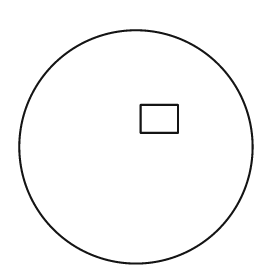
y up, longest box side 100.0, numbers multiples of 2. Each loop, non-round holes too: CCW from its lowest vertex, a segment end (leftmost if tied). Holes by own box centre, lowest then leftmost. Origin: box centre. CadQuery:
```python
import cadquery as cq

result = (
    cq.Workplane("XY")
    .moveTo(0.0, 0.0)
    .circle(50.0)
    .moveTo(2.0, 6.0)
    .lineTo(18.0, 6.0)
    .lineTo(18.0, 18.0)
    .lineTo(2.0, 18.0)
    .close()
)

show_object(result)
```